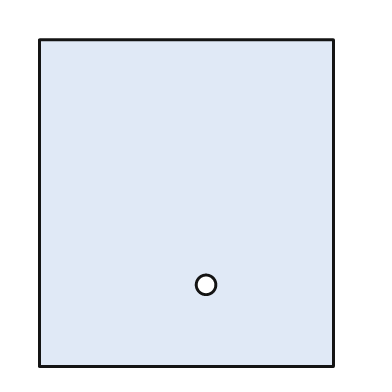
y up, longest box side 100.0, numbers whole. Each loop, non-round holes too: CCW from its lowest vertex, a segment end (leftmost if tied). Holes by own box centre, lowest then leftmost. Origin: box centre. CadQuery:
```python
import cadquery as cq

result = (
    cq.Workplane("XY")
    .moveTo(-45.0, -50.0)
    .lineTo(45.0, -50.0)
    .lineTo(45.0, 50.0)
    .lineTo(-45.0, 50.0)
    .close()
    .moveTo(6.0, -25.0)
    .circle(3.0)
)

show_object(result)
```